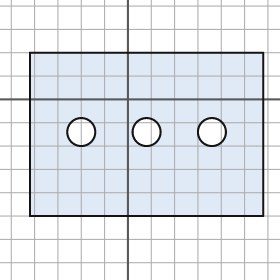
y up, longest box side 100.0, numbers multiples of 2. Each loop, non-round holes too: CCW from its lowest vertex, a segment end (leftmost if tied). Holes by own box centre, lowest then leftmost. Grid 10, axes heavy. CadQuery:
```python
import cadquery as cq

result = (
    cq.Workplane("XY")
    .moveTo(-42.0, -50.0)
    .lineTo(58.0, -50.0)
    .lineTo(58.0, 20.0)
    .lineTo(-42.0, 20.0)
    .close()
    .moveTo(-20.0, -14.0)
    .circle(6.0)
    .moveTo(8.0, -14.0)
    .circle(6.0)
    .moveTo(36.0, -14.0)
    .circle(6.0)
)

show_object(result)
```